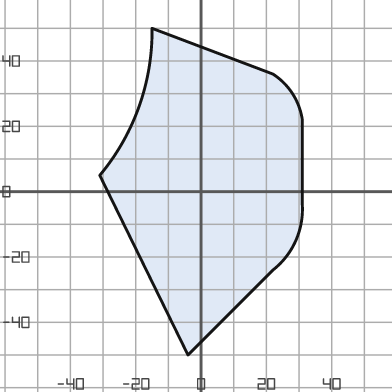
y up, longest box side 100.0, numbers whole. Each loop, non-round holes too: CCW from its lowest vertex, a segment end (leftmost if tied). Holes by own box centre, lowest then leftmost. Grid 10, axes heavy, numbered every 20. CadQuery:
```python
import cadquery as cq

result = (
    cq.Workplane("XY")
    .moveTo(-4.0, -50.0)
    .lineTo(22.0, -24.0)
    .threePointArc((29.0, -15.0), (31.0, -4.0))
    .lineTo(31.0, 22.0)
    .threePointArc((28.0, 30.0), (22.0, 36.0))
    .lineTo(-15.0, 50.0)
    .threePointArc((-19.0, 26.0), (-31.0, 5.0))
    .close()
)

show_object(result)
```